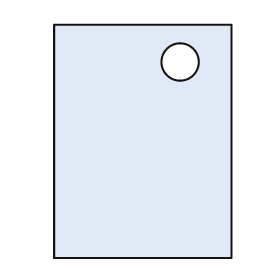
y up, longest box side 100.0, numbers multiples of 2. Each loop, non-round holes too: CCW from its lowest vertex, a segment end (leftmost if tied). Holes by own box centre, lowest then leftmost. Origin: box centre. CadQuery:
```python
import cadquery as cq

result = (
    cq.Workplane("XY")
    .moveTo(-38.0, -50.0)
    .lineTo(38.0, -50.0)
    .lineTo(38.0, 50.0)
    .lineTo(-38.0, 50.0)
    .close()
    .moveTo(16.0, 34.0)
    .circle(8.0)
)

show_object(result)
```